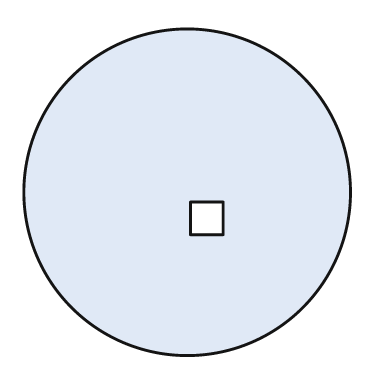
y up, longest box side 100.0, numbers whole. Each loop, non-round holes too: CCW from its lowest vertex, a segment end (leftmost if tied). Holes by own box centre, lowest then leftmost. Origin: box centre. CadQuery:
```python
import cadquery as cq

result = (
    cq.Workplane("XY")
    .moveTo(0.0, 0.0)
    .circle(50.0)
    .moveTo(1.0, -13.0)
    .lineTo(11.0, -13.0)
    .lineTo(11.0, -3.0)
    .lineTo(1.0, -3.0)
    .close()
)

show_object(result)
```